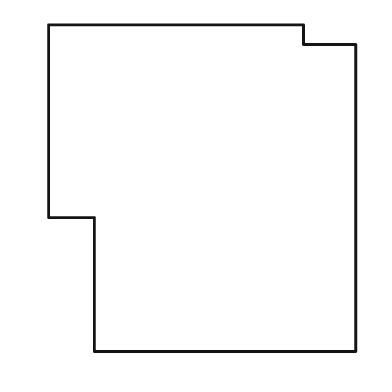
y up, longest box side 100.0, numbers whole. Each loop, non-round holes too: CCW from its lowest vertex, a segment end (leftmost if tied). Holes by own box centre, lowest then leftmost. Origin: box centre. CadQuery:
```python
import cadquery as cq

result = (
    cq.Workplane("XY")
    .moveTo(-33.0, -50.0)
    .lineTo(47.0, -50.0)
    .lineTo(47.0, 44.0)
    .lineTo(31.0, 44.0)
    .lineTo(31.0, 50.0)
    .lineTo(-47.0, 50.0)
    .lineTo(-47.0, -9.0)
    .lineTo(-33.0, -9.0)
    .close()
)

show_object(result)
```